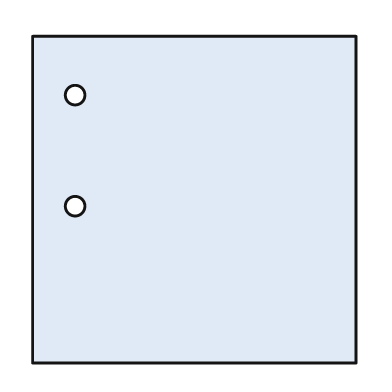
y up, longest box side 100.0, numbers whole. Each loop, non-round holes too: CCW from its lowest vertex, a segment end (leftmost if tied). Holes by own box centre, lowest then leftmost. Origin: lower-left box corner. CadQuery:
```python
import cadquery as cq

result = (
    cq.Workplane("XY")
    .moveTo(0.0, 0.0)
    .lineTo(99.0, 0.0)
    .lineTo(99.0, 100.0)
    .lineTo(0.0, 100.0)
    .close()
    .moveTo(13.0, 48.0)
    .circle(3.0)
    .moveTo(13.0, 82.0)
    .circle(3.0)
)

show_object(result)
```